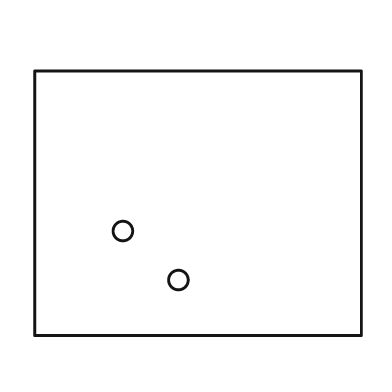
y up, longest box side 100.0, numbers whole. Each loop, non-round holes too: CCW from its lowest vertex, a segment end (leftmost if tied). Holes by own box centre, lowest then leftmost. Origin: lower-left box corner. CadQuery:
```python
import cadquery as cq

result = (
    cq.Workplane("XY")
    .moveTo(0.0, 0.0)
    .lineTo(100.0, 0.0)
    .lineTo(100.0, 81.0)
    .lineTo(0.0, 81.0)
    .close()
    .moveTo(44.0, 17.0)
    .circle(3.0)
    .moveTo(27.0, 32.0)
    .circle(3.0)
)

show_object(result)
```